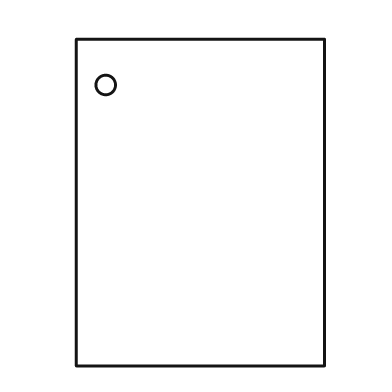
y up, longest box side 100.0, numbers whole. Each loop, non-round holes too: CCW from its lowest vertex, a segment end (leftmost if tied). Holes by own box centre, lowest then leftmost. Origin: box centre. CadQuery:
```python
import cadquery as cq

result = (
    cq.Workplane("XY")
    .moveTo(-38.0, -50.0)
    .lineTo(38.0, -50.0)
    .lineTo(38.0, 50.0)
    .lineTo(-38.0, 50.0)
    .close()
    .moveTo(-29.0, 36.0)
    .circle(3.0)
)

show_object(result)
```